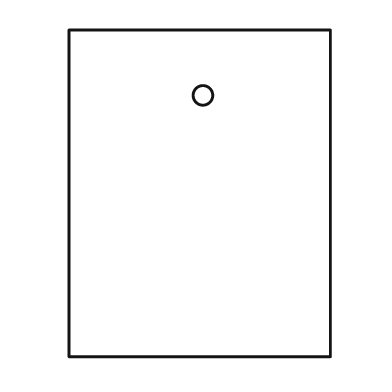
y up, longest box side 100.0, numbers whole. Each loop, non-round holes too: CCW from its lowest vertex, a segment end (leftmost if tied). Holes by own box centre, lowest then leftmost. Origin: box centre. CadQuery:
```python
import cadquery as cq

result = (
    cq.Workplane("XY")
    .moveTo(-40.0, -50.0)
    .lineTo(40.0, -50.0)
    .lineTo(40.0, 50.0)
    .lineTo(-40.0, 50.0)
    .close()
    .moveTo(1.0, 30.0)
    .circle(3.0)
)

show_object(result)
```